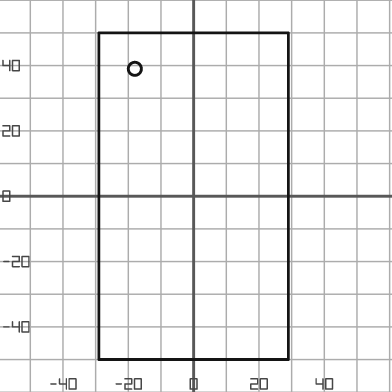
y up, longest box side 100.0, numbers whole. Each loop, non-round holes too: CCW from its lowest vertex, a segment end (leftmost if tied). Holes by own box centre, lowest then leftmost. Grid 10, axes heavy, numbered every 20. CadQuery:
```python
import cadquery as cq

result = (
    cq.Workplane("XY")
    .moveTo(-29.0, -50.0)
    .lineTo(29.0, -50.0)
    .lineTo(29.0, 50.0)
    .lineTo(-29.0, 50.0)
    .close()
    .moveTo(-18.0, 39.0)
    .circle(2.0)
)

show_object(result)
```